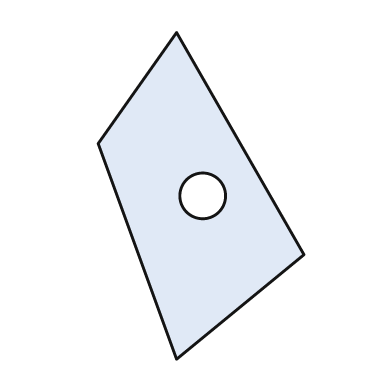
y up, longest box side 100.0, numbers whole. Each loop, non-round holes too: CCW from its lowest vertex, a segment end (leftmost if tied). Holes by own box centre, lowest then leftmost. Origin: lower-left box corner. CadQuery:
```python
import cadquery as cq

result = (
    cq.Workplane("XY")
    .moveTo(24.0, 0.0)
    .lineTo(63.0, 32.0)
    .lineTo(24.0, 100.0)
    .lineTo(0.0, 66.0)
    .close()
    .moveTo(32.0, 50.0)
    .circle(7.0)
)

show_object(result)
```